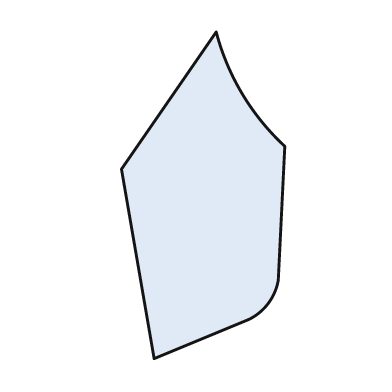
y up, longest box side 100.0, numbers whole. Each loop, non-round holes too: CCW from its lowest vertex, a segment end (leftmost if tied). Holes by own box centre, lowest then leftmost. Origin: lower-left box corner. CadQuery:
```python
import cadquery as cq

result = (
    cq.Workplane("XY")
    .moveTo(10.0, 0.0)
    .lineTo(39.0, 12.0)
    .threePointArc((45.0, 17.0), (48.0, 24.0))
    .lineTo(50.0, 65.0)
    .threePointArc((37.0, 81.0), (29.0, 100.0))
    .lineTo(0.0, 58.0)
    .close()
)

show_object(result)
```